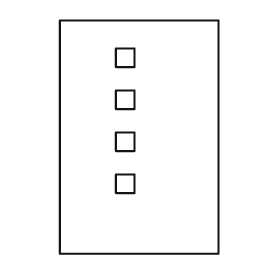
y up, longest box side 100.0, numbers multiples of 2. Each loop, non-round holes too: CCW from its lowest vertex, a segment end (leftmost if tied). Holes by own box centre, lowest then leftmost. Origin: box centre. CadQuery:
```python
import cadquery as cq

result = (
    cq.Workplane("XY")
    .moveTo(-34.0, -50.0)
    .lineTo(34.0, -50.0)
    .lineTo(34.0, 50.0)
    .lineTo(-34.0, 50.0)
    .close()
    .moveTo(-10.0, -24.0)
    .lineTo(-2.0, -24.0)
    .lineTo(-2.0, -16.0)
    .lineTo(-10.0, -16.0)
    .close()
    .moveTo(-10.0, -6.0)
    .lineTo(-2.0, -6.0)
    .lineTo(-2.0, 2.0)
    .lineTo(-10.0, 2.0)
    .close()
    .moveTo(-10.0, 12.0)
    .lineTo(-2.0, 12.0)
    .lineTo(-2.0, 20.0)
    .lineTo(-10.0, 20.0)
    .close()
    .moveTo(-10.0, 30.0)
    .lineTo(-2.0, 30.0)
    .lineTo(-2.0, 38.0)
    .lineTo(-10.0, 38.0)
    .close()
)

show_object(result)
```